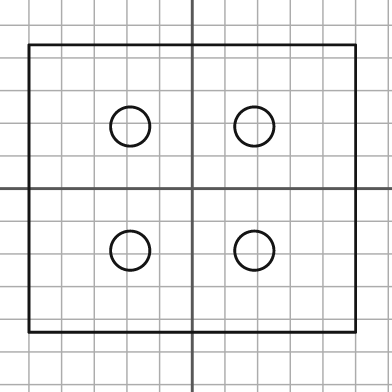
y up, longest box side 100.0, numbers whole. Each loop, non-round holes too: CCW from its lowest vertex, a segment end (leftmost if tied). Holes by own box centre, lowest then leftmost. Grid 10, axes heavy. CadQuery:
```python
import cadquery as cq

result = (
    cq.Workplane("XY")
    .moveTo(-50.0, -44.0)
    .lineTo(50.0, -44.0)
    .lineTo(50.0, 44.0)
    .lineTo(-50.0, 44.0)
    .close()
    .moveTo(-19.0, -19.0)
    .circle(6.0)
    .moveTo(19.0, -19.0)
    .circle(6.0)
    .moveTo(-19.0, 19.0)
    .circle(6.0)
    .moveTo(19.0, 19.0)
    .circle(6.0)
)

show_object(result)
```